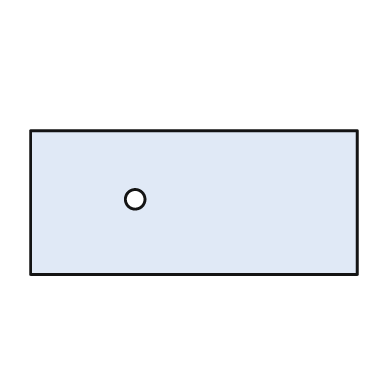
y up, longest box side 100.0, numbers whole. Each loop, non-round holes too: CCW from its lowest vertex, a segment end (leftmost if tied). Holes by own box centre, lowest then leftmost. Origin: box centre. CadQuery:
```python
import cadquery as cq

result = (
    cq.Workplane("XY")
    .moveTo(-50.0, -22.0)
    .lineTo(50.0, -22.0)
    .lineTo(50.0, 22.0)
    .lineTo(-50.0, 22.0)
    .close()
    .moveTo(-18.0, 1.0)
    .circle(3.0)
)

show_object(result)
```